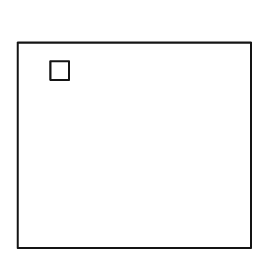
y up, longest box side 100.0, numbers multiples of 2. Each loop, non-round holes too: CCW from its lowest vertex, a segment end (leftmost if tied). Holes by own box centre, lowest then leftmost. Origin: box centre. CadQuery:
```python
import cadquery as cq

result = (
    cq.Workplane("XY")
    .moveTo(-50.0, -44.0)
    .lineTo(50.0, -44.0)
    .lineTo(50.0, 44.0)
    .lineTo(-50.0, 44.0)
    .close()
    .moveTo(-36.0, 28.0)
    .lineTo(-28.0, 28.0)
    .lineTo(-28.0, 36.0)
    .lineTo(-36.0, 36.0)
    .close()
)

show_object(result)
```